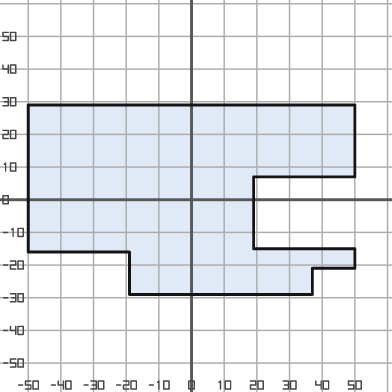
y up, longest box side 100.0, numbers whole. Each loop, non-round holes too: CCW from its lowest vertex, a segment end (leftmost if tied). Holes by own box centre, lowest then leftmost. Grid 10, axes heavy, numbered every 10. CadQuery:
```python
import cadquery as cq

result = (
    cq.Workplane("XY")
    .moveTo(-19.0, -29.0)
    .lineTo(37.0, -29.0)
    .lineTo(37.0, -21.0)
    .lineTo(50.0, -21.0)
    .lineTo(50.0, -15.0)
    .lineTo(19.0, -15.0)
    .lineTo(19.0, 7.0)
    .lineTo(50.0, 7.0)
    .lineTo(50.0, 29.0)
    .lineTo(-50.0, 29.0)
    .lineTo(-50.0, -16.0)
    .lineTo(-19.0, -16.0)
    .close()
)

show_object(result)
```